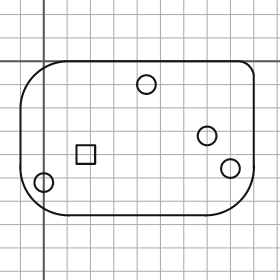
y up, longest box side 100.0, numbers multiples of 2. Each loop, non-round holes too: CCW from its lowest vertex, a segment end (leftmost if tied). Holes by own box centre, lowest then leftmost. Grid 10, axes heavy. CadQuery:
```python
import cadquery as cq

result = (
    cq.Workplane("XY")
    .moveTo(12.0, -66.0)
    .lineTo(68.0, -66.0)
    .threePointArc((84.0, -60.0), (90.0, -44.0))
    .lineTo(90.0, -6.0)
    .threePointArc((88.0, -2.0), (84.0, 0.0))
    .lineTo(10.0, 0.0)
    .threePointArc((-4.0, -6.0), (-10.0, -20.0))
    .lineTo(-10.0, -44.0)
    .threePointArc((-4.0, -60.0), (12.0, -66.0))
    .close()
    .moveTo(0.0, -52.0)
    .circle(4.0)
    .moveTo(80.0, -46.0)
    .circle(4.0)
    .moveTo(14.0, -44.0)
    .lineTo(22.0, -44.0)
    .lineTo(22.0, -36.0)
    .lineTo(14.0, -36.0)
    .close()
    .moveTo(70.0, -32.0)
    .circle(4.0)
    .moveTo(44.0, -10.0)
    .circle(4.0)
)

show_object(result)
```